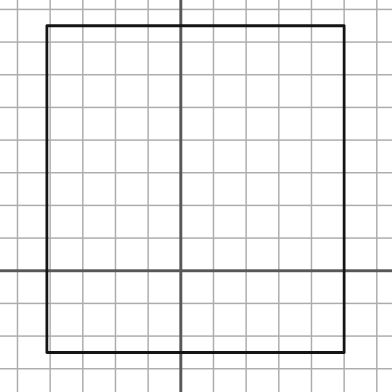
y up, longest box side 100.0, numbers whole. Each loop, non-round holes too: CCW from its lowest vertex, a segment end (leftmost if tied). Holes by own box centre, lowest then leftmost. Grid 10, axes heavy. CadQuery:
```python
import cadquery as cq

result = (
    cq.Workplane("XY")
    .moveTo(-41.0, -25.0)
    .lineTo(50.0, -25.0)
    .lineTo(50.0, 75.0)
    .lineTo(-41.0, 75.0)
    .close()
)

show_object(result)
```